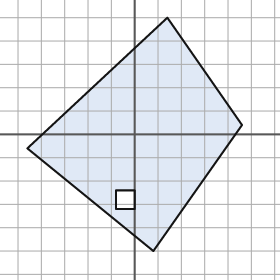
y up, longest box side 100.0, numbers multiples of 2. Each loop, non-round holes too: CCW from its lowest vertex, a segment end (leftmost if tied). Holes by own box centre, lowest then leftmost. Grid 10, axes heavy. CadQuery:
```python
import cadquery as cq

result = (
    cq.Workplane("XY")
    .moveTo(8.0, -50.0)
    .lineTo(46.0, 4.0)
    .lineTo(14.0, 50.0)
    .lineTo(-46.0, -6.0)
    .close()
    .moveTo(-8.0, -32.0)
    .lineTo(0.0, -32.0)
    .lineTo(0.0, -24.0)
    .lineTo(-8.0, -24.0)
    .close()
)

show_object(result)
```